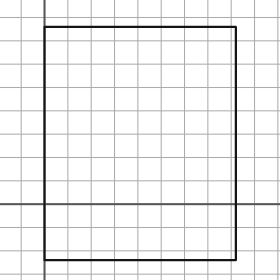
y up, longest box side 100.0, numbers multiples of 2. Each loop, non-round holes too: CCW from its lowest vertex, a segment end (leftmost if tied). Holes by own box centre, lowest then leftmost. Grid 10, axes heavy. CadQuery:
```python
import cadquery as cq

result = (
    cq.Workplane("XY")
    .moveTo(0.0, -24.0)
    .lineTo(82.0, -24.0)
    .lineTo(82.0, 76.0)
    .lineTo(0.0, 76.0)
    .close()
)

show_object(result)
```